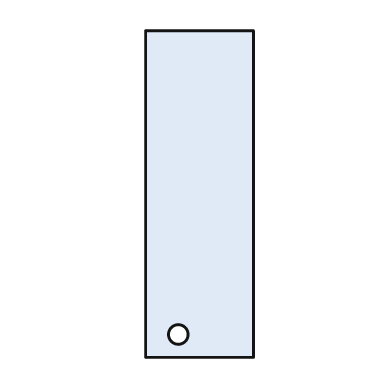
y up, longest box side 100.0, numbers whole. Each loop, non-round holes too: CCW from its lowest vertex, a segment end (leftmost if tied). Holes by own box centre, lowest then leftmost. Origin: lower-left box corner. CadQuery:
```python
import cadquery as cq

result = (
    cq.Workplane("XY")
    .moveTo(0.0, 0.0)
    .lineTo(33.0, 0.0)
    .lineTo(33.0, 100.0)
    .lineTo(0.0, 100.0)
    .close()
    .moveTo(10.0, 7.0)
    .circle(3.0)
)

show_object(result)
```